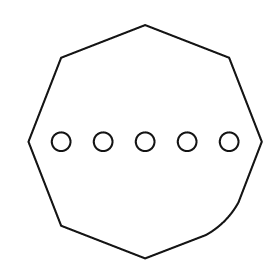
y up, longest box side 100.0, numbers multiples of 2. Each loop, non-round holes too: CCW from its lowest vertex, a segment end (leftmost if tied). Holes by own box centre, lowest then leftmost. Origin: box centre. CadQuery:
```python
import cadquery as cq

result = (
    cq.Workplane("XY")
    .moveTo(0.0, -50.0)
    .lineTo(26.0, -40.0)
    .threePointArc((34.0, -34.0), (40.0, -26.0))
    .lineTo(50.0, 0.0)
    .lineTo(36.0, 36.0)
    .lineTo(0.0, 50.0)
    .lineTo(-36.0, 36.0)
    .lineTo(-50.0, 0.0)
    .lineTo(-36.0, -36.0)
    .close()
    .moveTo(-36.0, 0.0)
    .circle(4.0)
    .moveTo(-18.0, 0.0)
    .circle(4.0)
    .moveTo(0.0, 0.0)
    .circle(4.0)
    .moveTo(18.0, 0.0)
    .circle(4.0)
    .moveTo(36.0, 0.0)
    .circle(4.0)
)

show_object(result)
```